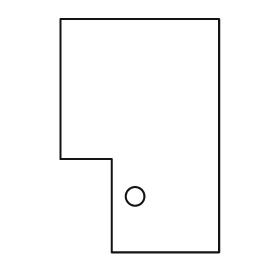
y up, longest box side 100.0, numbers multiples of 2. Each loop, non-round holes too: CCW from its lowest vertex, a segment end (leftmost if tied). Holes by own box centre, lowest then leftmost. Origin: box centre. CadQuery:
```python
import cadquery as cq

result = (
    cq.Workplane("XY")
    .moveTo(-12.0, -50.0)
    .lineTo(34.0, -50.0)
    .lineTo(34.0, 50.0)
    .lineTo(-34.0, 50.0)
    .lineTo(-34.0, -10.0)
    .lineTo(-12.0, -10.0)
    .close()
    .moveTo(-2.0, -26.0)
    .circle(4.0)
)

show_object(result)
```